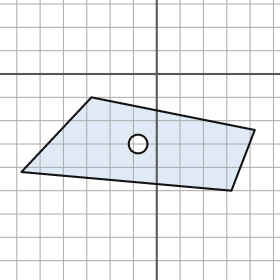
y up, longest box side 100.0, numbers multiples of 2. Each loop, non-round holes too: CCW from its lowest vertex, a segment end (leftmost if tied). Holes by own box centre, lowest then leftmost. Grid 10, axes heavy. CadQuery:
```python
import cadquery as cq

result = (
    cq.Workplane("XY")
    .moveTo(32.0, -50.0)
    .lineTo(42.0, -24.0)
    .lineTo(-28.0, -10.0)
    .lineTo(-58.0, -42.0)
    .close()
    .moveTo(-8.0, -30.0)
    .circle(4.0)
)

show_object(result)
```